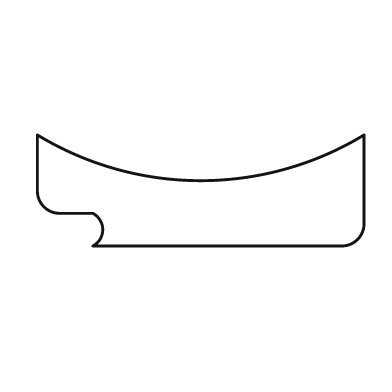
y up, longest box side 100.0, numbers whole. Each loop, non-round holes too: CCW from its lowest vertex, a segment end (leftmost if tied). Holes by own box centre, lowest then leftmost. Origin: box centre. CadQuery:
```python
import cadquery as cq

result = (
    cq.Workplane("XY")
    .moveTo(-33.0, -17.0)
    .lineTo(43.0, -17.0)
    .threePointArc((48.0, -15.0), (50.0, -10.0))
    .lineTo(50.0, 17.0)
    .threePointArc((0.0, 3.0), (-50.0, 17.0))
    .lineTo(-50.0, 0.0)
    .threePointArc((-48.0, -5.0), (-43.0, -7.0))
    .lineTo(-33.0, -7.0)
    .threePointArc((-30.0, -12.0), (-33.0, -17.0))
    .close()
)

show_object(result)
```